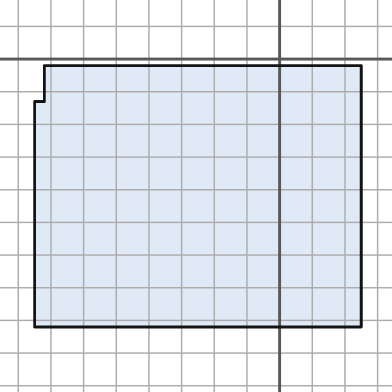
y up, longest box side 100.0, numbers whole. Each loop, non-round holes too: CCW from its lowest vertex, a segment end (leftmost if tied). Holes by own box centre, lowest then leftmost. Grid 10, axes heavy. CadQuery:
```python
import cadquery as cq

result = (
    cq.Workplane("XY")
    .moveTo(-75.0, -82.0)
    .lineTo(25.0, -82.0)
    .lineTo(25.0, -2.0)
    .lineTo(-72.0, -2.0)
    .lineTo(-72.0, -13.0)
    .lineTo(-75.0, -13.0)
    .close()
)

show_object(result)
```